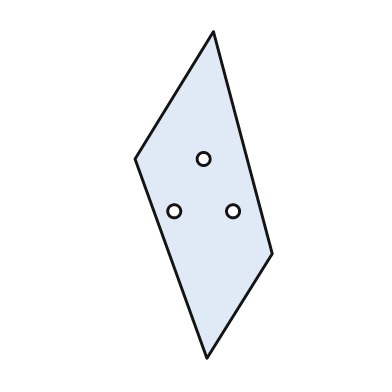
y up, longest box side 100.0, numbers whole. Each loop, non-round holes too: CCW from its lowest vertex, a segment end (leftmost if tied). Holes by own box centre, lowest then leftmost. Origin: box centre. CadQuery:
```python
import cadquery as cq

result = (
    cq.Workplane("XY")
    .moveTo(1.0, -50.0)
    .lineTo(21.0, -18.0)
    .lineTo(3.0, 50.0)
    .lineTo(-21.0, 11.0)
    .close()
    .moveTo(-9.0, -5.0)
    .circle(2.0)
    .moveTo(9.0, -5.0)
    .circle(2.0)
    .moveTo(0.0, 11.0)
    .circle(2.0)
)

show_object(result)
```